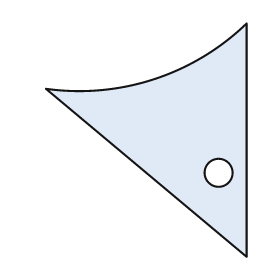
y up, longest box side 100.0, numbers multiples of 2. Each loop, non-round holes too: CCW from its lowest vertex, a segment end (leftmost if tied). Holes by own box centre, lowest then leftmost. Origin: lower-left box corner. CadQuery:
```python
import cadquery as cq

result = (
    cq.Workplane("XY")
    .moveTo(86.0, 0.0)
    .lineTo(86.0, 100.0)
    .threePointArc((46.0, 76.0), (0.0, 72.0))
    .close()
    .moveTo(74.0, 36.0)
    .circle(6.0)
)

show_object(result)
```